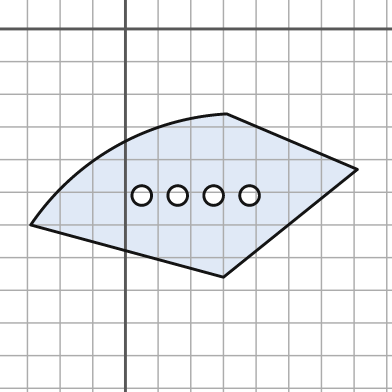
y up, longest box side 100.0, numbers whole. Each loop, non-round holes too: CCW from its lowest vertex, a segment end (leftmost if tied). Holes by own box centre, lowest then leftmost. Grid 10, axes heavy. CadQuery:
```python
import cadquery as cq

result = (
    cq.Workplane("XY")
    .moveTo(30.0, -76.0)
    .lineTo(71.0, -43.0)
    .lineTo(31.0, -26.0)
    .threePointArc((-3.0, -36.0), (-29.0, -60.0))
    .close()
    .moveTo(5.0, -51.0)
    .circle(3.0)
    .moveTo(16.0, -51.0)
    .circle(3.0)
    .moveTo(27.0, -51.0)
    .circle(3.0)
    .moveTo(38.0, -51.0)
    .circle(3.0)
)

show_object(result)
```